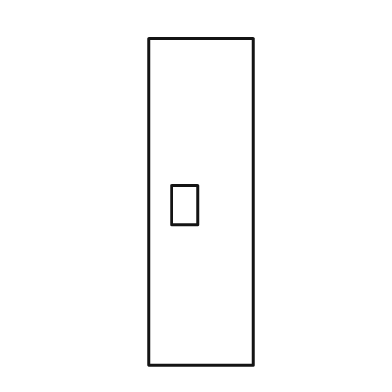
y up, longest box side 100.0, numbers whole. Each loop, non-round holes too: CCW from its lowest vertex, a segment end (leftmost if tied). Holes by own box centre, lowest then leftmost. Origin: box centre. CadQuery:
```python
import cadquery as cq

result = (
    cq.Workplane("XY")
    .moveTo(-16.0, -50.0)
    .lineTo(16.0, -50.0)
    .lineTo(16.0, 50.0)
    .lineTo(-16.0, 50.0)
    .close()
    .moveTo(-9.0, -7.0)
    .lineTo(-1.0, -7.0)
    .lineTo(-1.0, 5.0)
    .lineTo(-9.0, 5.0)
    .close()
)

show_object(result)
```